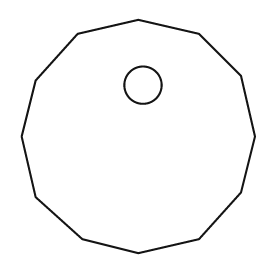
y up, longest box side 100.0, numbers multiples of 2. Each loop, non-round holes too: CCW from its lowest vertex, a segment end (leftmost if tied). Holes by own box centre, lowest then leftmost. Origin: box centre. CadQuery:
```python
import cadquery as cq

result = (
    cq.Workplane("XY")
    .moveTo(0.0, -50.0)
    .lineTo(26.0, -44.0)
    .lineTo(44.0, -24.0)
    .lineTo(50.0, 0.0)
    .lineTo(44.0, 26.0)
    .lineTo(26.0, 44.0)
    .lineTo(0.0, 50.0)
    .lineTo(-26.0, 44.0)
    .lineTo(-44.0, 24.0)
    .lineTo(-50.0, 0.0)
    .lineTo(-44.0, -26.0)
    .lineTo(-24.0, -44.0)
    .close()
    .moveTo(2.0, 22.0)
    .circle(8.0)
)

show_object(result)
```